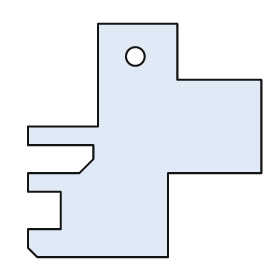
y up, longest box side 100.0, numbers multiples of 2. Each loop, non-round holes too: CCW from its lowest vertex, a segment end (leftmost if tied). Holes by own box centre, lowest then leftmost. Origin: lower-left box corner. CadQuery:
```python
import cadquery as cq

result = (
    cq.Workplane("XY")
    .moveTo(4.0, 0.0)
    .lineTo(60.0, 0.0)
    .lineTo(60.0, 36.0)
    .lineTo(100.0, 36.0)
    .lineTo(100.0, 76.0)
    .lineTo(64.0, 76.0)
    .lineTo(64.0, 100.0)
    .lineTo(30.0, 100.0)
    .lineTo(30.0, 56.0)
    .lineTo(0.0, 56.0)
    .lineTo(0.0, 48.0)
    .lineTo(28.0, 48.0)
    .lineTo(28.0, 42.0)
    .lineTo(22.0, 36.0)
    .lineTo(0.0, 36.0)
    .lineTo(0.0, 28.0)
    .lineTo(14.0, 28.0)
    .lineTo(14.0, 12.0)
    .lineTo(0.0, 12.0)
    .lineTo(0.0, 4.0)
    .close()
    .moveTo(46.0, 86.0)
    .circle(4.0)
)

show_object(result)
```